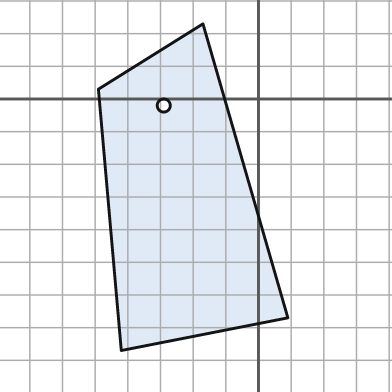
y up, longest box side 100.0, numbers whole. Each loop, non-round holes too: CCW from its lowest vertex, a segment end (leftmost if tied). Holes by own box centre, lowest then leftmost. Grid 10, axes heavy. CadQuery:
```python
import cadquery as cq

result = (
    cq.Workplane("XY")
    .moveTo(-42.0, -77.0)
    .lineTo(9.0, -67.0)
    .lineTo(-17.0, 23.0)
    .lineTo(-49.0, 3.0)
    .close()
    .moveTo(-29.0, -2.0)
    .circle(2.0)
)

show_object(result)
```